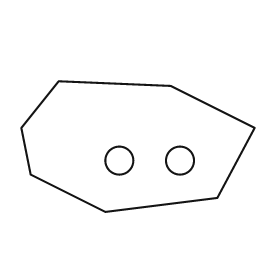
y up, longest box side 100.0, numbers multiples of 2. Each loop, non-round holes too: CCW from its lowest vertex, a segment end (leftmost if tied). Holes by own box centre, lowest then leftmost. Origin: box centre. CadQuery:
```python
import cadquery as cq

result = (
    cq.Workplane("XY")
    .moveTo(-14.0, -28.0)
    .lineTo(34.0, -22.0)
    .lineTo(50.0, 8.0)
    .lineTo(14.0, 26.0)
    .lineTo(-34.0, 28.0)
    .lineTo(-50.0, 8.0)
    .lineTo(-46.0, -12.0)
    .close()
    .moveTo(-8.0, -6.0)
    .circle(6.0)
    .moveTo(18.0, -6.0)
    .circle(6.0)
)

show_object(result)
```